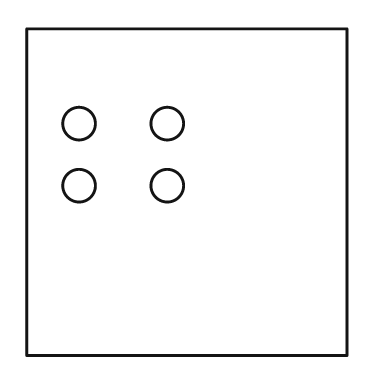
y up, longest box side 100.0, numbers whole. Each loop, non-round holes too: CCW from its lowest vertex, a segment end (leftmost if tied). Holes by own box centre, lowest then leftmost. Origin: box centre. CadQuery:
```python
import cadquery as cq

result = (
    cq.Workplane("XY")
    .moveTo(-49.0, -50.0)
    .lineTo(49.0, -50.0)
    .lineTo(49.0, 50.0)
    .lineTo(-49.0, 50.0)
    .close()
    .moveTo(-33.0, 2.0)
    .circle(5.0)
    .moveTo(-6.0, 2.0)
    .circle(5.0)
    .moveTo(-33.0, 21.0)
    .circle(5.0)
    .moveTo(-6.0, 21.0)
    .circle(5.0)
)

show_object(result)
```